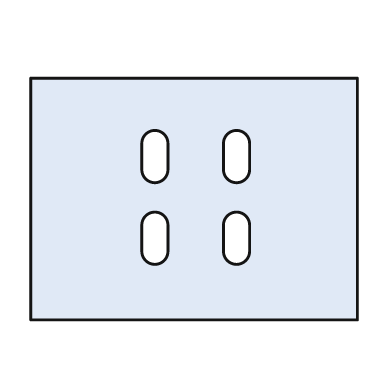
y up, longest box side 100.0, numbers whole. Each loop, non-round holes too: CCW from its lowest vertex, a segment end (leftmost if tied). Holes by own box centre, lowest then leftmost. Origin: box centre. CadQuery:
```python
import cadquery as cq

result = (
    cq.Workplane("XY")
    .moveTo(-50.0, -37.0)
    .lineTo(50.0, -37.0)
    .lineTo(50.0, 37.0)
    .lineTo(-50.0, 37.0)
    .close()
    .moveTo(-16.0, -16.0)
    .threePointArc((-12.0, -20.0), (-8.0, -16.0))
    .lineTo(-8.0, -8.0)
    .threePointArc((-12.0, -4.0), (-16.0, -8.0))
    .close()
    .moveTo(9.0, -16.0)
    .threePointArc((13.0, -20.0), (17.0, -16.0))
    .lineTo(17.0, -8.0)
    .threePointArc((13.0, -4.0), (9.0, -8.0))
    .close()
    .moveTo(-16.0, 9.0)
    .threePointArc((-12.0, 5.0), (-8.0, 9.0))
    .lineTo(-8.0, 17.0)
    .threePointArc((-12.0, 21.0), (-16.0, 17.0))
    .close()
    .moveTo(9.0, 9.0)
    .threePointArc((13.0, 5.0), (17.0, 9.0))
    .lineTo(17.0, 17.0)
    .threePointArc((13.0, 21.0), (9.0, 17.0))
    .close()
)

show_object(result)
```